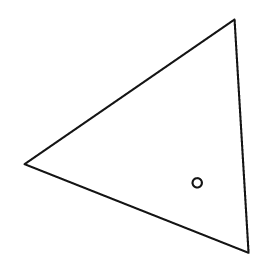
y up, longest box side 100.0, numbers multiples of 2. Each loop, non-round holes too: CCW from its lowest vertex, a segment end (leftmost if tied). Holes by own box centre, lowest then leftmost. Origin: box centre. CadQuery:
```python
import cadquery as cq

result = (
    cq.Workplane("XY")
    .moveTo(48.0, -50.0)
    .lineTo(42.0, 50.0)
    .lineTo(-48.0, -12.0)
    .close()
    .moveTo(26.0, -20.0)
    .circle(2.0)
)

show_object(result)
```